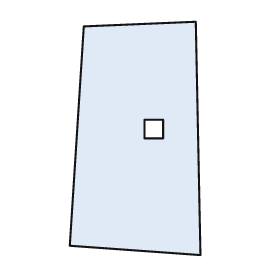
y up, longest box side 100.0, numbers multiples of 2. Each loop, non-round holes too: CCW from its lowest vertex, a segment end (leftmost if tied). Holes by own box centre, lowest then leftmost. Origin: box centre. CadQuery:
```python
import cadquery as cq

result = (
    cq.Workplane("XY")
    .moveTo(28.0, -50.0)
    .lineTo(26.0, 50.0)
    .lineTo(-22.0, 48.0)
    .lineTo(-28.0, -46.0)
    .close()
    .moveTo(4.0, 0.0)
    .lineTo(12.0, 0.0)
    .lineTo(12.0, 8.0)
    .lineTo(4.0, 8.0)
    .close()
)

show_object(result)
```